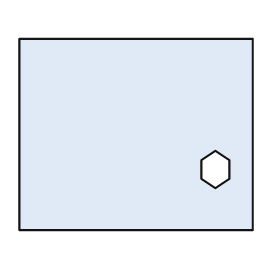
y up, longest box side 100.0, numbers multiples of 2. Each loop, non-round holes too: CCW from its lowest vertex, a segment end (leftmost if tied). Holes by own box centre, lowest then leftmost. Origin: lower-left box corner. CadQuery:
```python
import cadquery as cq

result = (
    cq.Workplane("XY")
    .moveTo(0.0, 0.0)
    .lineTo(100.0, 0.0)
    .lineTo(100.0, 82.0)
    .lineTo(0.0, 82.0)
    .close()
    .moveTo(84.0, 18.0)
    .lineTo(90.0, 22.0)
    .lineTo(90.0, 30.0)
    .lineTo(84.0, 34.0)
    .lineTo(78.0, 30.0)
    .lineTo(78.0, 22.0)
    .close()
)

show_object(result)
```